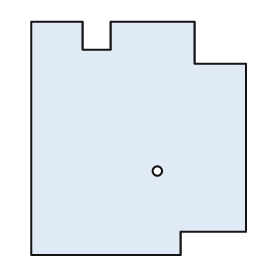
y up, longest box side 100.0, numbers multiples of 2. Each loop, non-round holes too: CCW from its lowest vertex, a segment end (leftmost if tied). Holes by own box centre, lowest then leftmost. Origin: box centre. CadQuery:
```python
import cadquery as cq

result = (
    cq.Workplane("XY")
    .moveTo(-46.0, -50.0)
    .lineTo(18.0, -50.0)
    .lineTo(18.0, -40.0)
    .lineTo(46.0, -40.0)
    .lineTo(46.0, 32.0)
    .lineTo(24.0, 32.0)
    .lineTo(24.0, 50.0)
    .lineTo(-12.0, 50.0)
    .lineTo(-12.0, 38.0)
    .lineTo(-24.0, 38.0)
    .lineTo(-24.0, 50.0)
    .lineTo(-46.0, 50.0)
    .close()
    .moveTo(8.0, -14.0)
    .circle(2.0)
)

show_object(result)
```